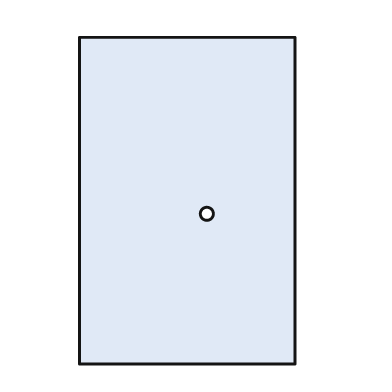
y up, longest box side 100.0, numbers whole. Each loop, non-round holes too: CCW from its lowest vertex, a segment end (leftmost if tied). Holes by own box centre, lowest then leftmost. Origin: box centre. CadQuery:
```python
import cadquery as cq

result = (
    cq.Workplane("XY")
    .moveTo(-33.0, -50.0)
    .lineTo(33.0, -50.0)
    .lineTo(33.0, 50.0)
    .lineTo(-33.0, 50.0)
    .close()
    .moveTo(6.0, -4.0)
    .circle(2.0)
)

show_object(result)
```